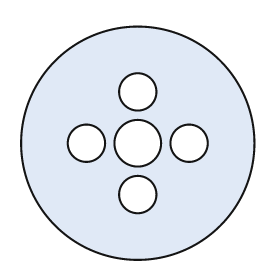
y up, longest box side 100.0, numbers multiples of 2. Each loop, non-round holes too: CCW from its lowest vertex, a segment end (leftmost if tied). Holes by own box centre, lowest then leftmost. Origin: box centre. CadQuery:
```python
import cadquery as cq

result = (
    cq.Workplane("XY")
    .moveTo(0.0, 0.0)
    .circle(50.0)
    .moveTo(0.0, -22.0)
    .circle(8.0)
    .moveTo(-22.0, 0.0)
    .circle(8.0)
    .moveTo(0.0, 0.0)
    .circle(10.0)
    .moveTo(22.0, 0.0)
    .circle(8.0)
    .moveTo(0.0, 22.0)
    .circle(8.0)
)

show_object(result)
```